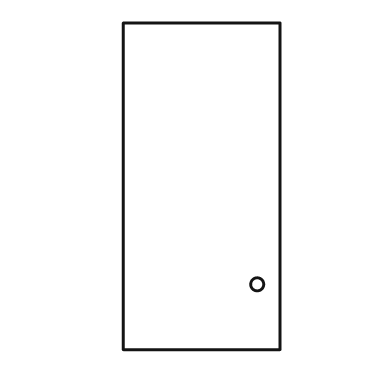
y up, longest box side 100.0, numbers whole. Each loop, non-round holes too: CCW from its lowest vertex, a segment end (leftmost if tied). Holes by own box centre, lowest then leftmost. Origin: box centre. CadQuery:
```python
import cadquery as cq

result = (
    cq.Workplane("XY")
    .moveTo(-24.0, -50.0)
    .lineTo(24.0, -50.0)
    .lineTo(24.0, 50.0)
    .lineTo(-24.0, 50.0)
    .close()
    .moveTo(17.0, -30.0)
    .circle(2.0)
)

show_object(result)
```